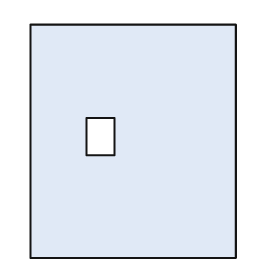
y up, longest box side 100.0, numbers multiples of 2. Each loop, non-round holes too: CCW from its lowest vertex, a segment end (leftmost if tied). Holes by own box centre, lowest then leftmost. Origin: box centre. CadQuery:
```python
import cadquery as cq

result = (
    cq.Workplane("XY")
    .moveTo(-44.0, -50.0)
    .lineTo(44.0, -50.0)
    .lineTo(44.0, 50.0)
    .lineTo(-44.0, 50.0)
    .close()
    .moveTo(-20.0, -6.0)
    .lineTo(-8.0, -6.0)
    .lineTo(-8.0, 10.0)
    .lineTo(-20.0, 10.0)
    .close()
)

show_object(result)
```